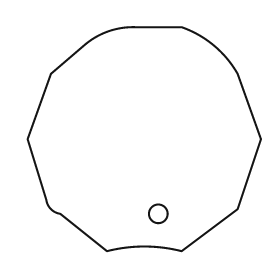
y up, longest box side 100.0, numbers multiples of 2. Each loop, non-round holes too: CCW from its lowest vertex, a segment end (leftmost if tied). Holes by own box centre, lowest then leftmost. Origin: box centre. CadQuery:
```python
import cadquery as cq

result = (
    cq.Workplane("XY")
    .moveTo(-16.0, -48.0)
    .threePointArc((0.0, -46.0), (16.0, -48.0))
    .lineTo(40.0, -30.0)
    .lineTo(50.0, 0.0)
    .lineTo(40.0, 28.0)
    .threePointArc((30.0, 40.0), (16.0, 48.0))
    .lineTo(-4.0, 48.0)
    .threePointArc((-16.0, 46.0), (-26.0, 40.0))
    .lineTo(-40.0, 28.0)
    .lineTo(-50.0, 0.0)
    .lineTo(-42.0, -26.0)
    .threePointArc((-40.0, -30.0), (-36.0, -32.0))
    .close()
    .moveTo(6.0, -32.0)
    .circle(4.0)
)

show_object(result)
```